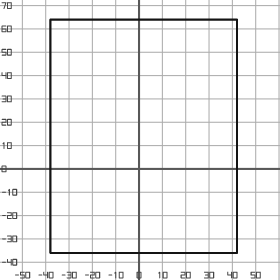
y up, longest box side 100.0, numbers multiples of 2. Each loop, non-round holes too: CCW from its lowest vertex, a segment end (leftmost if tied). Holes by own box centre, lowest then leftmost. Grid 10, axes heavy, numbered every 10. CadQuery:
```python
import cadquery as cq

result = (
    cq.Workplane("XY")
    .moveTo(-38.0, -36.0)
    .lineTo(42.0, -36.0)
    .lineTo(42.0, 64.0)
    .lineTo(-38.0, 64.0)
    .close()
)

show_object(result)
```